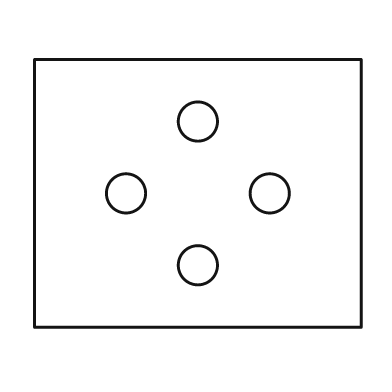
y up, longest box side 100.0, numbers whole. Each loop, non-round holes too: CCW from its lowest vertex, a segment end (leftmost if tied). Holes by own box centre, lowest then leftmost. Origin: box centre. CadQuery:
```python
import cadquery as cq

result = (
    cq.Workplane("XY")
    .moveTo(-50.0, -41.0)
    .lineTo(50.0, -41.0)
    .lineTo(50.0, 41.0)
    .lineTo(-50.0, 41.0)
    .close()
    .moveTo(0.0, -22.0)
    .circle(6.0)
    .moveTo(-22.0, 0.0)
    .circle(6.0)
    .moveTo(22.0, 0.0)
    .circle(6.0)
    .moveTo(0.0, 22.0)
    .circle(6.0)
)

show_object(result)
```